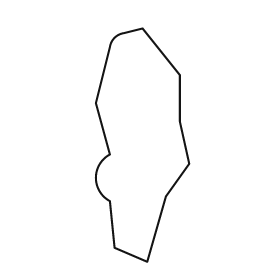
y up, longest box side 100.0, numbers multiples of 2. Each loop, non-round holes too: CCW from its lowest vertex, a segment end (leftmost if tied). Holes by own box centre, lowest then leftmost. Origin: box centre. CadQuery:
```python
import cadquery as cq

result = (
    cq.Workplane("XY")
    .moveTo(2.0, -50.0)
    .lineTo(10.0, -22.0)
    .lineTo(20.0, -8.0)
    .lineTo(16.0, 10.0)
    .lineTo(16.0, 30.0)
    .lineTo(0.0, 50.0)
    .lineTo(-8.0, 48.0)
    .threePointArc((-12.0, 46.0), (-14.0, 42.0))
    .lineTo(-20.0, 18.0)
    .lineTo(-14.0, -4.0)
    .threePointArc((-20.0, -14.0), (-14.0, -24.0))
    .lineTo(-12.0, -44.0)
    .close()
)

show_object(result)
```